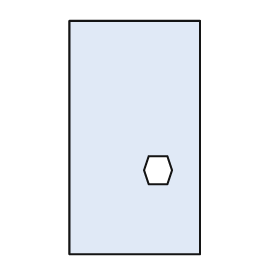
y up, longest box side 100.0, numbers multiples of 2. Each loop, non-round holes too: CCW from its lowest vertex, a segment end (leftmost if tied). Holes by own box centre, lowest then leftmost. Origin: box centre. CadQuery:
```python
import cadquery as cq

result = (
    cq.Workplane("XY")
    .moveTo(-28.0, -50.0)
    .lineTo(28.0, -50.0)
    .lineTo(28.0, 50.0)
    .lineTo(-28.0, 50.0)
    .close()
    .moveTo(6.0, -20.0)
    .lineTo(14.0, -20.0)
    .lineTo(16.0, -14.0)
    .lineTo(14.0, -8.0)
    .lineTo(6.0, -8.0)
    .lineTo(4.0, -14.0)
    .close()
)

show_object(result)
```